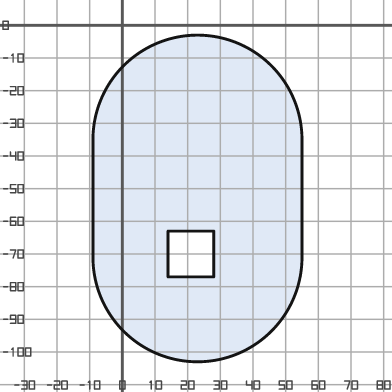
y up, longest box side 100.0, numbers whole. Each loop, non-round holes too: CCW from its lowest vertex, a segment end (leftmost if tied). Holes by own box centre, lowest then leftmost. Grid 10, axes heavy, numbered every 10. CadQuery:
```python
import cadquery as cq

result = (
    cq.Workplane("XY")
    .moveTo(-9.0, -71.0)
    .threePointArc((23.0, -103.0), (55.0, -71.0))
    .lineTo(55.0, -35.0)
    .threePointArc((23.0, -3.0), (-9.0, -35.0))
    .close()
    .moveTo(14.0, -77.0)
    .lineTo(28.0, -77.0)
    .lineTo(28.0, -63.0)
    .lineTo(14.0, -63.0)
    .close()
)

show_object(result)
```